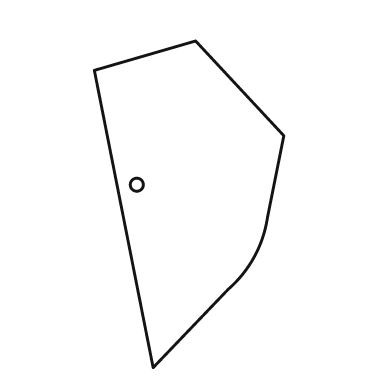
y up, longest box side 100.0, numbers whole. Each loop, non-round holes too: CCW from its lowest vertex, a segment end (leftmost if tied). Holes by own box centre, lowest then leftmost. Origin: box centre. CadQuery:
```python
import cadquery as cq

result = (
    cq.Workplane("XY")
    .moveTo(-11.0, -50.0)
    .lineTo(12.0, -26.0)
    .threePointArc((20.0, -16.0), (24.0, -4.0))
    .lineTo(29.0, 21.0)
    .lineTo(2.0, 50.0)
    .lineTo(-29.0, 41.0)
    .close()
    .moveTo(-16.0, 6.0)
    .circle(2.0)
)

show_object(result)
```